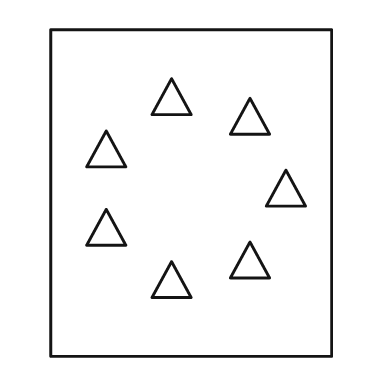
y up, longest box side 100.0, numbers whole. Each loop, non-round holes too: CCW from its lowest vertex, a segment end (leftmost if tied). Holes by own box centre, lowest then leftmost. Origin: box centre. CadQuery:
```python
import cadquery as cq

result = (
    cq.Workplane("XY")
    .moveTo(-43.0, -50.0)
    .lineTo(43.0, -50.0)
    .lineTo(43.0, 50.0)
    .lineTo(-43.0, 50.0)
    .close()
    .moveTo(-12.0, -32.0)
    .lineTo(0.0, -32.0)
    .lineTo(-6.0, -21.0)
    .close()
    .moveTo(12.0, -26.0)
    .lineTo(24.0, -26.0)
    .lineTo(18.0, -15.0)
    .close()
    .moveTo(-32.0, -16.0)
    .lineTo(-20.0, -16.0)
    .lineTo(-26.0, -5.0)
    .close()
    .moveTo(23.0, -4.0)
    .lineTo(35.0, -4.0)
    .lineTo(29.0, 7.0)
    .close()
    .moveTo(-32.0, 8.0)
    .lineTo(-20.0, 8.0)
    .lineTo(-26.0, 19.0)
    .close()
    .moveTo(12.0, 18.0)
    .lineTo(24.0, 18.0)
    .lineTo(18.0, 29.0)
    .close()
    .moveTo(-12.0, 24.0)
    .lineTo(0.0, 24.0)
    .lineTo(-6.0, 35.0)
    .close()
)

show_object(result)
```